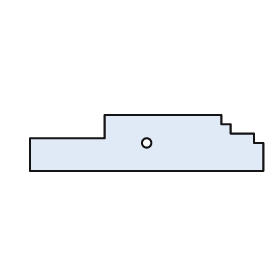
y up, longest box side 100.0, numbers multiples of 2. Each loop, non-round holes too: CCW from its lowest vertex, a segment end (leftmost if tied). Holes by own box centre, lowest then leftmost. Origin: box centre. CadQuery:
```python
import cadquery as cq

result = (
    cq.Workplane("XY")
    .moveTo(-50.0, -12.0)
    .lineTo(50.0, -12.0)
    .lineTo(50.0, 0.0)
    .lineTo(46.0, 0.0)
    .lineTo(46.0, 4.0)
    .lineTo(36.0, 4.0)
    .lineTo(36.0, 8.0)
    .lineTo(32.0, 8.0)
    .lineTo(32.0, 12.0)
    .lineTo(-18.0, 12.0)
    .lineTo(-18.0, 2.0)
    .lineTo(-50.0, 2.0)
    .close()
    .moveTo(0.0, 0.0)
    .circle(2.0)
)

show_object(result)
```